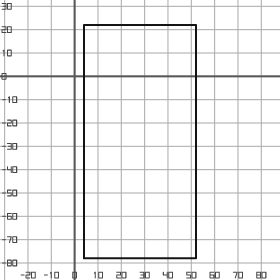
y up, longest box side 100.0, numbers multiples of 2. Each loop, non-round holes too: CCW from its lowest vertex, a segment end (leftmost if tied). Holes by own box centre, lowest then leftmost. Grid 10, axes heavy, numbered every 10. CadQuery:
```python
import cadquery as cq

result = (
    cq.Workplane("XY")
    .moveTo(4.0, -78.0)
    .lineTo(52.0, -78.0)
    .lineTo(52.0, 22.0)
    .lineTo(4.0, 22.0)
    .close()
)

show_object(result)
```